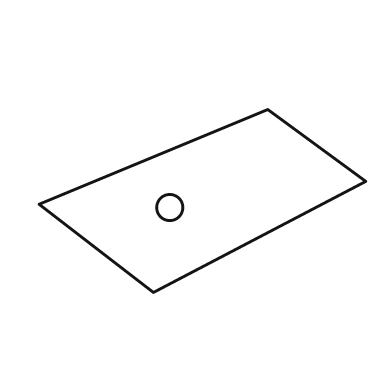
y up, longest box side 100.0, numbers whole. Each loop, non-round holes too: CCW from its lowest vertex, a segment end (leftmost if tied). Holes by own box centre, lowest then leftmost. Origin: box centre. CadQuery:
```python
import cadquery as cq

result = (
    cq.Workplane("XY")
    .moveTo(-15.0, -28.0)
    .lineTo(50.0, 6.0)
    .lineTo(20.0, 28.0)
    .lineTo(-50.0, -1.0)
    .close()
    .moveTo(-10.0, -2.0)
    .circle(4.0)
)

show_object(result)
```